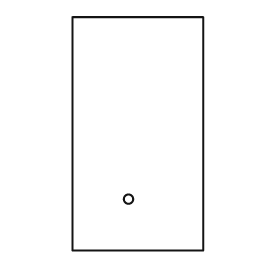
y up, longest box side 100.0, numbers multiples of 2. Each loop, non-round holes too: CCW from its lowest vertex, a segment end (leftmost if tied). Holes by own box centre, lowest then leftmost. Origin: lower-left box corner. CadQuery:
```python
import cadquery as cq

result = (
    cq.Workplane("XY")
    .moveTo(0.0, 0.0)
    .lineTo(56.0, 0.0)
    .lineTo(56.0, 100.0)
    .lineTo(0.0, 100.0)
    .close()
    .moveTo(24.0, 22.0)
    .circle(2.0)
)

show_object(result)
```